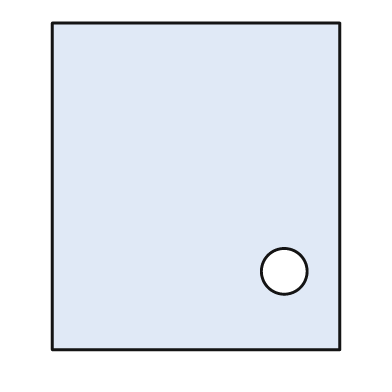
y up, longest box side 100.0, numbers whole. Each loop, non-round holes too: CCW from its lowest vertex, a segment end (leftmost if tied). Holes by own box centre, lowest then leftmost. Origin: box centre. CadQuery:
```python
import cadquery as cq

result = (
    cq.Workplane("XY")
    .moveTo(-44.0, -50.0)
    .lineTo(44.0, -50.0)
    .lineTo(44.0, 50.0)
    .lineTo(-44.0, 50.0)
    .close()
    .moveTo(27.0, -26.0)
    .circle(7.0)
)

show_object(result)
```